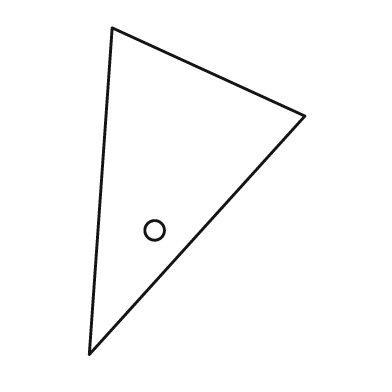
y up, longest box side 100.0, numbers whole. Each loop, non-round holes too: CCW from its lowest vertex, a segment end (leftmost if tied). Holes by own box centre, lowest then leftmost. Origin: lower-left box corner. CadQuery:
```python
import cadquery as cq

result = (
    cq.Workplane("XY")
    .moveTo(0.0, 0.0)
    .lineTo(66.0, 73.0)
    .lineTo(7.0, 100.0)
    .close()
    .moveTo(20.0, 38.0)
    .circle(3.0)
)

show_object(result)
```